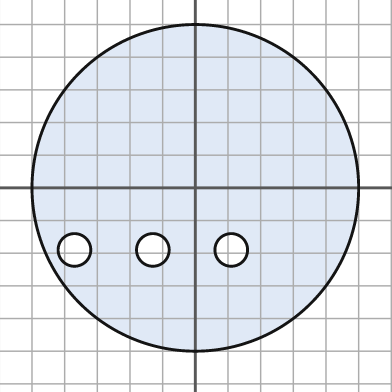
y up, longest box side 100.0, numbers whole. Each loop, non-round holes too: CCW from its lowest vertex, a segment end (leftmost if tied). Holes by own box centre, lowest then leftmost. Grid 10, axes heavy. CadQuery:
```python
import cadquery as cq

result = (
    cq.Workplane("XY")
    .moveTo(0.0, 0.0)
    .circle(50.0)
    .moveTo(-37.0, -19.0)
    .circle(5.0)
    .moveTo(-13.0, -19.0)
    .circle(5.0)
    .moveTo(11.0, -19.0)
    .circle(5.0)
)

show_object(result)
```